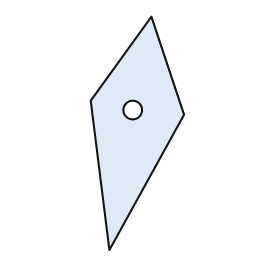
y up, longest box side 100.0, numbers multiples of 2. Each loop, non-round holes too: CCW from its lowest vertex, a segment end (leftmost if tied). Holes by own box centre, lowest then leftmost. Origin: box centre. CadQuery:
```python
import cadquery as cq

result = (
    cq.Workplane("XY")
    .moveTo(-12.0, -50.0)
    .lineTo(20.0, 8.0)
    .lineTo(6.0, 50.0)
    .lineTo(-20.0, 14.0)
    .close()
    .moveTo(-2.0, 10.0)
    .circle(4.0)
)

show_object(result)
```